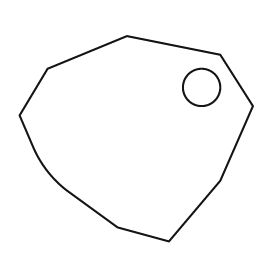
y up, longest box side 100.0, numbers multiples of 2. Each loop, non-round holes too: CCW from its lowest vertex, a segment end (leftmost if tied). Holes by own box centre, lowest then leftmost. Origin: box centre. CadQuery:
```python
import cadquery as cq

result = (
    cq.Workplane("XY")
    .moveTo(14.0, -44.0)
    .lineTo(36.0, -18.0)
    .lineTo(50.0, 14.0)
    .lineTo(36.0, 36.0)
    .lineTo(-4.0, 44.0)
    .lineTo(-38.0, 30.0)
    .lineTo(-50.0, 10.0)
    .lineTo(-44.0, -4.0)
    .threePointArc((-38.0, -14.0), (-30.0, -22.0))
    .lineTo(-8.0, -38.0)
    .close()
    .moveTo(28.0, 22.0)
    .circle(8.0)
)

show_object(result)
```